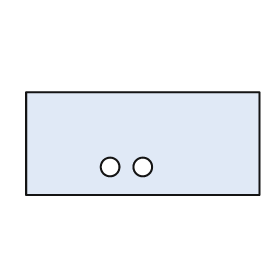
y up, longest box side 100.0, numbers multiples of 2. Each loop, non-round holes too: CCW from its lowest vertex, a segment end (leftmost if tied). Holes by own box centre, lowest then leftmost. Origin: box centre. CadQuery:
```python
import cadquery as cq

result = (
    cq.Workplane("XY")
    .moveTo(-50.0, -22.0)
    .lineTo(50.0, -22.0)
    .lineTo(50.0, 22.0)
    .lineTo(-50.0, 22.0)
    .close()
    .moveTo(-14.0, -10.0)
    .circle(4.0)
    .moveTo(0.0, -10.0)
    .circle(4.0)
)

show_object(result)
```